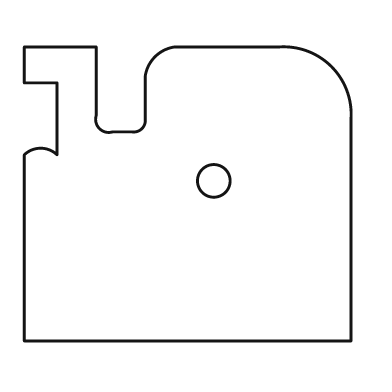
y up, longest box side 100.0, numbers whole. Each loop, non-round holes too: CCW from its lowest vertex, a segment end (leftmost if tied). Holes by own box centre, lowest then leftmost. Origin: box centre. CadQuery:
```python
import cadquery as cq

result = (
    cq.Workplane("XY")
    .moveTo(-50.0, -45.0)
    .lineTo(50.0, -45.0)
    .lineTo(50.0, 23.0)
    .threePointArc((44.0, 39.0), (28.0, 45.0))
    .lineTo(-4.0, 45.0)
    .threePointArc((-10.0, 42.0), (-13.0, 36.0))
    .lineTo(-13.0, 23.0)
    .threePointArc((-14.0, 20.0), (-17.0, 19.0))
    .lineTo(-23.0, 19.0)
    .threePointArc((-27.0, 20.0), (-28.0, 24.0))
    .lineTo(-28.0, 45.0)
    .lineTo(-50.0, 45.0)
    .lineTo(-50.0, 34.0)
    .lineTo(-40.0, 34.0)
    .lineTo(-40.0, 12.0)
    .threePointArc((-45.0, 14.0), (-50.0, 12.0))
    .close()
    .moveTo(8.0, 4.0)
    .circle(5.0)
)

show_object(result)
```